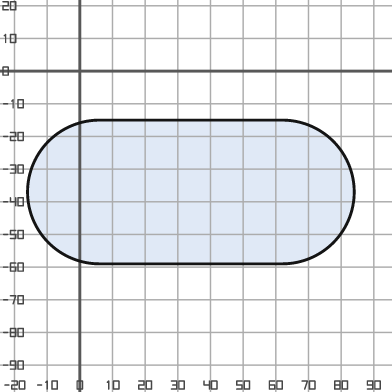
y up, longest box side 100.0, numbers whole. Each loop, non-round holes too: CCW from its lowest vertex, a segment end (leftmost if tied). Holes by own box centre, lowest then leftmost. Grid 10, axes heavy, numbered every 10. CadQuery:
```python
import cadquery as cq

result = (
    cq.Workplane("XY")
    .moveTo(6.0, -59.0)
    .lineTo(62.0, -59.0)
    .threePointArc((84.0, -37.0), (62.0, -15.0))
    .lineTo(6.0, -15.0)
    .threePointArc((-16.0, -37.0), (6.0, -59.0))
    .close()
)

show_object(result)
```